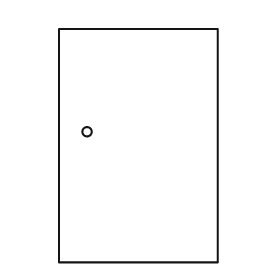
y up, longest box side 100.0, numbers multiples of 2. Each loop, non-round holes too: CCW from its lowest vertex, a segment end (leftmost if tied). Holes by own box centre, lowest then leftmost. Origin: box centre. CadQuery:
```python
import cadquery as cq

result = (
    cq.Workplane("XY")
    .moveTo(-34.0, -50.0)
    .lineTo(34.0, -50.0)
    .lineTo(34.0, 50.0)
    .lineTo(-34.0, 50.0)
    .close()
    .moveTo(-22.0, 6.0)
    .circle(2.0)
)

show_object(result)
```